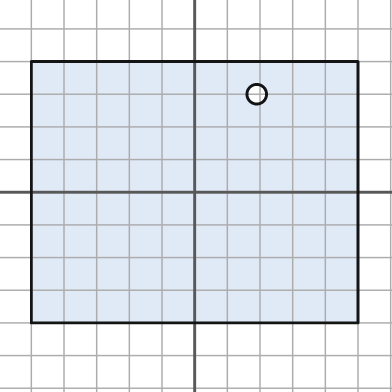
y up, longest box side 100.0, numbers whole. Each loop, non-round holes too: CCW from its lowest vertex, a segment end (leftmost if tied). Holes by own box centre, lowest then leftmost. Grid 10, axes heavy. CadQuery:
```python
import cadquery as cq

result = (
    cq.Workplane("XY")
    .moveTo(-50.0, -40.0)
    .lineTo(50.0, -40.0)
    .lineTo(50.0, 40.0)
    .lineTo(-50.0, 40.0)
    .close()
    .moveTo(19.0, 30.0)
    .circle(3.0)
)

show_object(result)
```